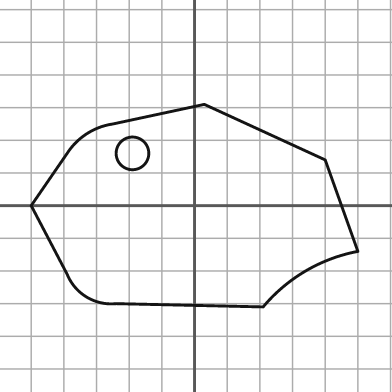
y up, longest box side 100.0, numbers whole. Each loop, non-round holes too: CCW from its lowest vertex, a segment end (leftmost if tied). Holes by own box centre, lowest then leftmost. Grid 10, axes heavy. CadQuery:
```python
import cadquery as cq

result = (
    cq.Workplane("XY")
    .moveTo(21.0, -31.0)
    .threePointArc((34.0, -20.0), (50.0, -14.0))
    .lineTo(40.0, 14.0)
    .lineTo(3.0, 31.0)
    .lineTo(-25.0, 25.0)
    .threePointArc((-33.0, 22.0), (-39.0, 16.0))
    .lineTo(-50.0, 0.0)
    .lineTo(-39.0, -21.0)
    .threePointArc((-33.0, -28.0), (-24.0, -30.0))
    .close()
    .moveTo(-19.0, 16.0)
    .circle(5.0)
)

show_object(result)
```